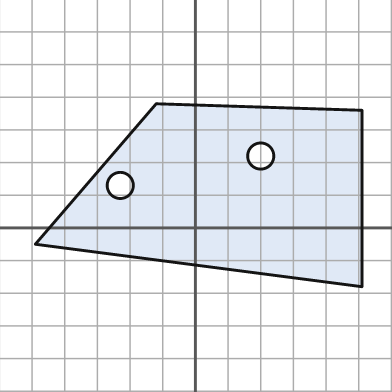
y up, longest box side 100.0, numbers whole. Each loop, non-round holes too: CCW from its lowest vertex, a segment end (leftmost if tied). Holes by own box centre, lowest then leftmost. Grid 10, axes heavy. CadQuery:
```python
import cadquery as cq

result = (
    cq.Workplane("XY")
    .moveTo(51.0, -18.0)
    .lineTo(51.0, 36.0)
    .lineTo(-12.0, 38.0)
    .lineTo(-49.0, -5.0)
    .close()
    .moveTo(-23.0, 13.0)
    .circle(4.0)
    .moveTo(20.0, 22.0)
    .circle(4.0)
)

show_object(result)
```